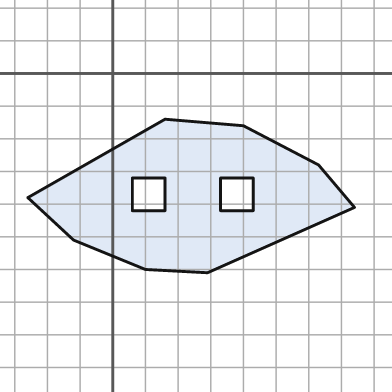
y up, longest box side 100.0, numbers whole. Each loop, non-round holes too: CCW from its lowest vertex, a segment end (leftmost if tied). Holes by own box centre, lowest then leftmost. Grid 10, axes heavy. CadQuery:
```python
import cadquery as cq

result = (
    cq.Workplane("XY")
    .moveTo(29.0, -61.0)
    .lineTo(74.0, -41.0)
    .lineTo(63.0, -28.0)
    .lineTo(40.0, -16.0)
    .lineTo(16.0, -14.0)
    .lineTo(-26.0, -38.0)
    .lineTo(-12.0, -51.0)
    .lineTo(10.0, -60.0)
    .close()
    .moveTo(6.0, -42.0)
    .lineTo(16.0, -42.0)
    .lineTo(16.0, -32.0)
    .lineTo(6.0, -32.0)
    .close()
    .moveTo(33.0, -42.0)
    .lineTo(43.0, -42.0)
    .lineTo(43.0, -32.0)
    .lineTo(33.0, -32.0)
    .close()
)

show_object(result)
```